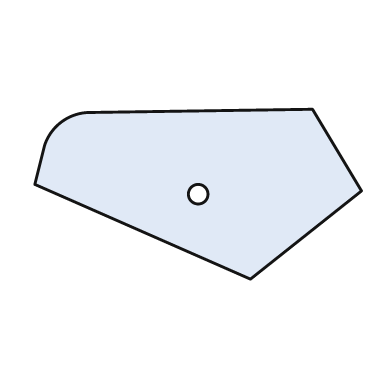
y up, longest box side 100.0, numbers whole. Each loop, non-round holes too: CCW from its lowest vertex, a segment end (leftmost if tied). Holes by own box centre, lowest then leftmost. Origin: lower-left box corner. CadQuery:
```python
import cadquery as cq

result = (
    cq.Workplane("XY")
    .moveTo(66.0, 0.0)
    .lineTo(100.0, 27.0)
    .lineTo(85.0, 52.0)
    .lineTo(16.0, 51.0)
    .threePointArc((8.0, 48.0), (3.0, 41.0))
    .lineTo(0.0, 29.0)
    .close()
    .moveTo(50.0, 26.0)
    .circle(3.0)
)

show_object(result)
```